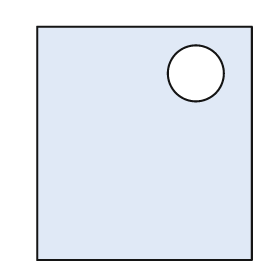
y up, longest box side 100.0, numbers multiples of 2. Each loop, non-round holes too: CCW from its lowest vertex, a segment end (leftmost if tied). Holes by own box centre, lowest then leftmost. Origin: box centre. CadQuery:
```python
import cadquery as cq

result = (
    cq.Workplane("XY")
    .moveTo(-46.0, -50.0)
    .lineTo(46.0, -50.0)
    .lineTo(46.0, 50.0)
    .lineTo(-46.0, 50.0)
    .close()
    .moveTo(22.0, 30.0)
    .circle(12.0)
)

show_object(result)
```